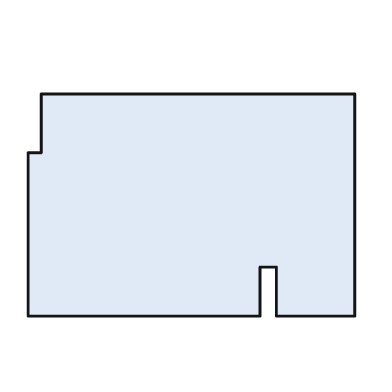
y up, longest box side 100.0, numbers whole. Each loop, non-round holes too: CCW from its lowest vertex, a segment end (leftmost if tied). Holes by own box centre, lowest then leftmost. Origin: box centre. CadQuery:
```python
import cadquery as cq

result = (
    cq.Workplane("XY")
    .moveTo(-50.0, -34.0)
    .lineTo(21.0, -34.0)
    .lineTo(21.0, -19.0)
    .lineTo(26.0, -19.0)
    .lineTo(26.0, -34.0)
    .lineTo(50.0, -34.0)
    .lineTo(50.0, 34.0)
    .lineTo(-46.0, 34.0)
    .lineTo(-46.0, 16.0)
    .lineTo(-50.0, 16.0)
    .close()
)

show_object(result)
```